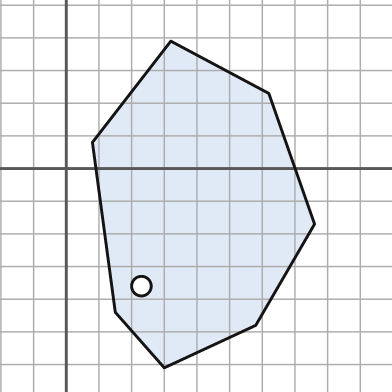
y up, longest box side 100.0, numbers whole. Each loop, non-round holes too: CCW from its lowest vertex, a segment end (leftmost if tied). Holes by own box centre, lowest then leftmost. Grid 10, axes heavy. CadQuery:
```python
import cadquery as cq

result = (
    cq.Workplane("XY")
    .moveTo(30.0, -61.0)
    .lineTo(58.0, -48.0)
    .lineTo(76.0, -17.0)
    .lineTo(62.0, 23.0)
    .lineTo(32.0, 39.0)
    .lineTo(8.0, 8.0)
    .lineTo(15.0, -44.0)
    .close()
    .moveTo(23.0, -36.0)
    .circle(3.0)
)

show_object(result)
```